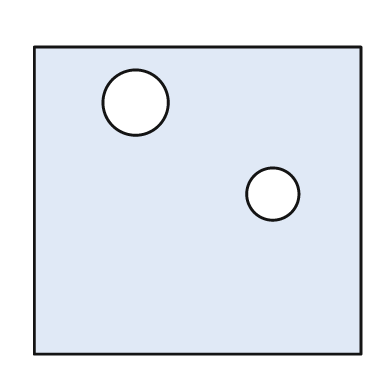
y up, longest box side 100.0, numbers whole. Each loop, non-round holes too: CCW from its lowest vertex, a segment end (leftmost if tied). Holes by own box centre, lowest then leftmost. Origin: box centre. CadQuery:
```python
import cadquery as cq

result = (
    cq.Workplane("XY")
    .moveTo(-50.0, -47.0)
    .lineTo(50.0, -47.0)
    .lineTo(50.0, 47.0)
    .lineTo(-50.0, 47.0)
    .close()
    .moveTo(23.0, 2.0)
    .circle(8.0)
    .moveTo(-19.0, 30.0)
    .circle(10.0)
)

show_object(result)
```